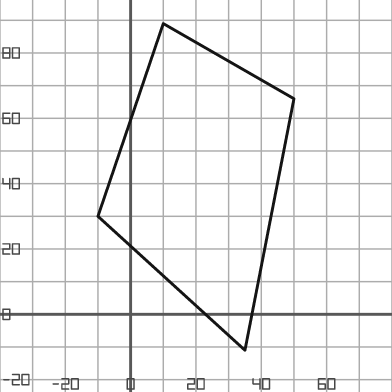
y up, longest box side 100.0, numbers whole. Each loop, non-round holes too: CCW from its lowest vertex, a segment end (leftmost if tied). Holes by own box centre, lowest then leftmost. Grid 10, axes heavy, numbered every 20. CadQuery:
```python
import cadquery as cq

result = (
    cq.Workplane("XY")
    .moveTo(35.0, -11.0)
    .lineTo(50.0, 66.0)
    .lineTo(10.0, 89.0)
    .lineTo(-10.0, 30.0)
    .close()
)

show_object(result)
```